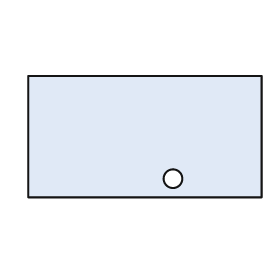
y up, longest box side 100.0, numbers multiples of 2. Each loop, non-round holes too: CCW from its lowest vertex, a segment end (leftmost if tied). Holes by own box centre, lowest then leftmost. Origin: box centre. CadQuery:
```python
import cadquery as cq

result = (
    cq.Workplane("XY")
    .moveTo(-50.0, -26.0)
    .lineTo(50.0, -26.0)
    .lineTo(50.0, 26.0)
    .lineTo(-50.0, 26.0)
    .close()
    .moveTo(12.0, -18.0)
    .circle(4.0)
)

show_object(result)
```